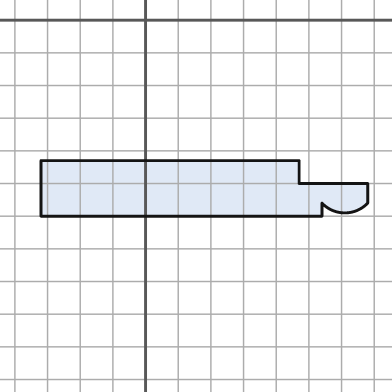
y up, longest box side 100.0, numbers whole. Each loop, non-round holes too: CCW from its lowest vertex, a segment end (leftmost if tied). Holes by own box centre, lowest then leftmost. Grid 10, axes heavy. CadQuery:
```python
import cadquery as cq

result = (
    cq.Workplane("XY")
    .moveTo(-32.0, -60.0)
    .lineTo(54.0, -60.0)
    .lineTo(54.0, -56.0)
    .threePointArc((61.0, -59.0), (68.0, -56.0))
    .lineTo(68.0, -50.0)
    .lineTo(47.0, -50.0)
    .lineTo(47.0, -43.0)
    .lineTo(-32.0, -43.0)
    .close()
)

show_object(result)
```